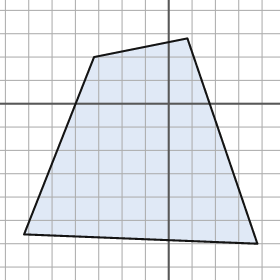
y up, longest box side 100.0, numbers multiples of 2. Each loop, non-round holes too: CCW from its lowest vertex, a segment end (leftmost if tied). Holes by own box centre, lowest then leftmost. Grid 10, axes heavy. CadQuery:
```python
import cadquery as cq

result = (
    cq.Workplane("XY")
    .moveTo(38.0, -60.0)
    .lineTo(8.0, 28.0)
    .lineTo(-32.0, 20.0)
    .lineTo(-62.0, -56.0)
    .close()
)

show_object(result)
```